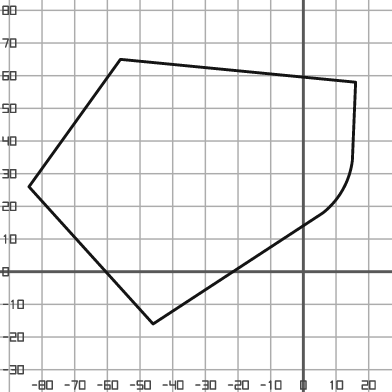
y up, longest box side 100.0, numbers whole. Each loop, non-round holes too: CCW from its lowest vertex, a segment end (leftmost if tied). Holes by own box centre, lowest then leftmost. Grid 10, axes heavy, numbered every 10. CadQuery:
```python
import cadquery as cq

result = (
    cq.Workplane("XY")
    .moveTo(-46.0, -16.0)
    .lineTo(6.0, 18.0)
    .threePointArc((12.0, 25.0), (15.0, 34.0))
    .lineTo(16.0, 58.0)
    .lineTo(-56.0, 65.0)
    .lineTo(-84.0, 26.0)
    .close()
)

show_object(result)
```